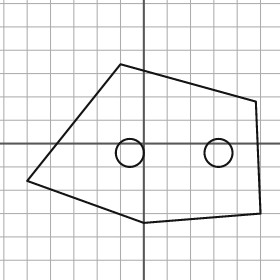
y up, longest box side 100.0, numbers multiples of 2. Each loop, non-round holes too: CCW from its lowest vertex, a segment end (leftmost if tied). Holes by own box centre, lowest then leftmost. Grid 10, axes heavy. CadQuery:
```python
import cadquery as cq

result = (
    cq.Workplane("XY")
    .moveTo(0.0, -34.0)
    .lineTo(50.0, -30.0)
    .lineTo(48.0, 18.0)
    .lineTo(-10.0, 34.0)
    .lineTo(-50.0, -16.0)
    .close()
    .moveTo(-6.0, -4.0)
    .circle(6.0)
    .moveTo(32.0, -4.0)
    .circle(6.0)
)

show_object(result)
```